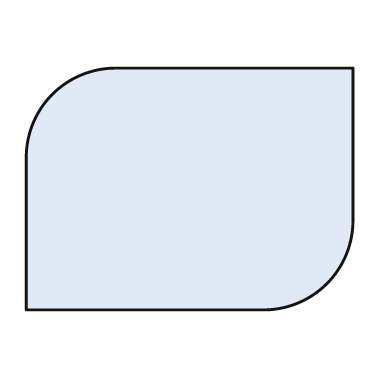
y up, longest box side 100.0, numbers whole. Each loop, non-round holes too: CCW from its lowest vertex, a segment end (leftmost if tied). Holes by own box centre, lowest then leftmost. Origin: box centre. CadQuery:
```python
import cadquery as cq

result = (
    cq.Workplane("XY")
    .moveTo(-50.0, -37.0)
    .lineTo(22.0, -37.0)
    .threePointArc((42.0, -29.0), (50.0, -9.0))
    .lineTo(50.0, 37.0)
    .lineTo(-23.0, 37.0)
    .threePointArc((-42.0, 29.0), (-50.0, 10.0))
    .close()
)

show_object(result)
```